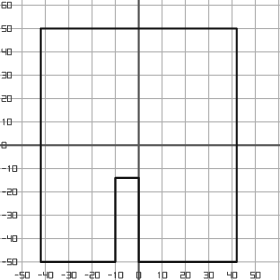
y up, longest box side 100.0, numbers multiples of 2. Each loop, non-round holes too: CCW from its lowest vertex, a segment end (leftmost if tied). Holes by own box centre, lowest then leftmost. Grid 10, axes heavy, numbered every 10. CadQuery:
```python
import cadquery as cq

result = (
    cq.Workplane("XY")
    .moveTo(-42.0, -50.0)
    .lineTo(-10.0, -50.0)
    .lineTo(-10.0, -14.0)
    .lineTo(0.0, -14.0)
    .lineTo(0.0, -50.0)
    .lineTo(42.0, -50.0)
    .lineTo(42.0, 50.0)
    .lineTo(-42.0, 50.0)
    .close()
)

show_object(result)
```